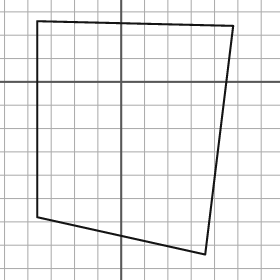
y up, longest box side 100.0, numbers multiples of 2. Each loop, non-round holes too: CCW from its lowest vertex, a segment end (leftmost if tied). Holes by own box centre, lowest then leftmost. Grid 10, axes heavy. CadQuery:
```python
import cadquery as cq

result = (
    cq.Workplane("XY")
    .moveTo(36.0, -74.0)
    .lineTo(48.0, 24.0)
    .lineTo(-36.0, 26.0)
    .lineTo(-36.0, -58.0)
    .close()
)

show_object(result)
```